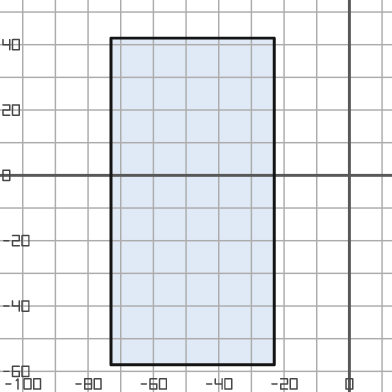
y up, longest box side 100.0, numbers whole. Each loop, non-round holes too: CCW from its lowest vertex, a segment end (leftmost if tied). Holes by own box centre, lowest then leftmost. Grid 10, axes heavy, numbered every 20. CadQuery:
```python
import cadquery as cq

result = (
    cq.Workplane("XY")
    .moveTo(-73.0, -58.0)
    .lineTo(-23.0, -58.0)
    .lineTo(-23.0, 42.0)
    .lineTo(-73.0, 42.0)
    .close()
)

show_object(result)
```